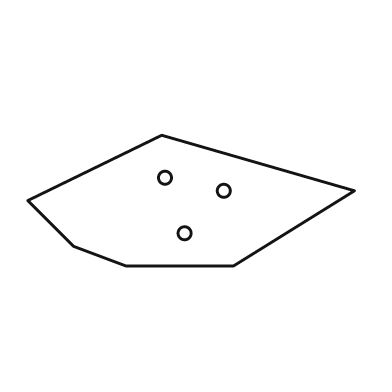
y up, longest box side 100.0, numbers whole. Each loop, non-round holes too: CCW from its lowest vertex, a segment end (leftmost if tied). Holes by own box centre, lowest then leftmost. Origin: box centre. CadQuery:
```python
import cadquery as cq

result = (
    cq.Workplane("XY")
    .moveTo(-20.0, -20.0)
    .lineTo(13.0, -20.0)
    .lineTo(50.0, 3.0)
    .lineTo(-9.0, 20.0)
    .lineTo(-50.0, 0.0)
    .lineTo(-36.0, -14.0)
    .close()
    .moveTo(-2.0, -10.0)
    .circle(2.0)
    .moveTo(10.0, 3.0)
    .circle(2.0)
    .moveTo(-8.0, 7.0)
    .circle(2.0)
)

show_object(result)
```